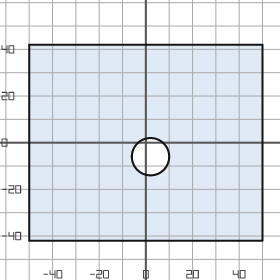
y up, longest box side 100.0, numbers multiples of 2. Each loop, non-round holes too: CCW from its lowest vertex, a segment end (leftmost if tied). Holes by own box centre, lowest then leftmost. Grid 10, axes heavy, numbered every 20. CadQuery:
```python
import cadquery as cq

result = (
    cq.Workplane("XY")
    .moveTo(-50.0, -42.0)
    .lineTo(50.0, -42.0)
    .lineTo(50.0, 42.0)
    .lineTo(-50.0, 42.0)
    .close()
    .moveTo(2.0, -6.0)
    .circle(8.0)
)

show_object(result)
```